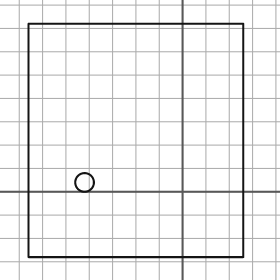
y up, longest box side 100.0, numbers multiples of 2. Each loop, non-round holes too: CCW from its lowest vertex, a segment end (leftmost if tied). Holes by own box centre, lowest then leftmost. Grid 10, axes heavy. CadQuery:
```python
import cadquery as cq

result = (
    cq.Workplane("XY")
    .moveTo(-66.0, -28.0)
    .lineTo(26.0, -28.0)
    .lineTo(26.0, 72.0)
    .lineTo(-66.0, 72.0)
    .close()
    .moveTo(-42.0, 4.0)
    .circle(4.0)
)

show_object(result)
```